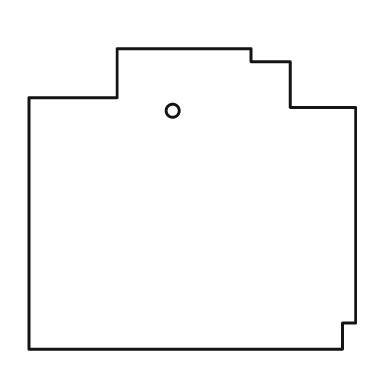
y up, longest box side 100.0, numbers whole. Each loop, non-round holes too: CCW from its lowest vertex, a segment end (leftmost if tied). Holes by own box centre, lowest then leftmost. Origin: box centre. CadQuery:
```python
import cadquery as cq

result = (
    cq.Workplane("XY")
    .moveTo(-50.0, -46.0)
    .lineTo(46.0, -46.0)
    .lineTo(46.0, -38.0)
    .lineTo(50.0, -38.0)
    .lineTo(50.0, 28.0)
    .lineTo(30.0, 28.0)
    .lineTo(30.0, 42.0)
    .lineTo(18.0, 42.0)
    .lineTo(18.0, 46.0)
    .lineTo(-23.0, 46.0)
    .lineTo(-23.0, 31.0)
    .lineTo(-50.0, 31.0)
    .close()
    .moveTo(-6.0, 27.0)
    .circle(2.0)
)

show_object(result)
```